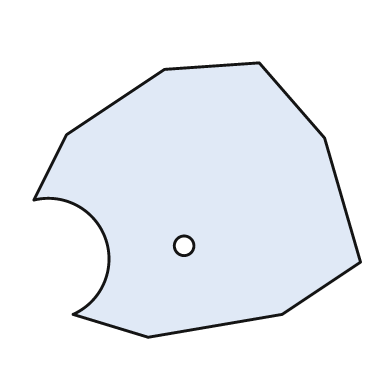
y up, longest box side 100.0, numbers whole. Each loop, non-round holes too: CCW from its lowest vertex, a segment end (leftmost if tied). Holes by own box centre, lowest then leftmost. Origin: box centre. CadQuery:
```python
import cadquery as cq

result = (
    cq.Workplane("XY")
    .moveTo(-15.0, -42.0)
    .lineTo(26.0, -35.0)
    .lineTo(50.0, -19.0)
    .lineTo(39.0, 19.0)
    .lineTo(19.0, 42.0)
    .lineTo(-10.0, 40.0)
    .lineTo(-40.0, 20.0)
    .lineTo(-50.0, 0.0)
    .threePointArc((-28.0, -12.0), (-38.0, -35.0))
    .close()
    .moveTo(-4.0, -14.0)
    .circle(3.0)
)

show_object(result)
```